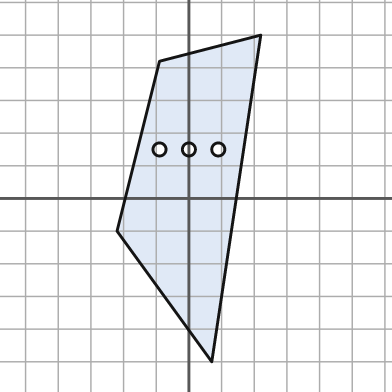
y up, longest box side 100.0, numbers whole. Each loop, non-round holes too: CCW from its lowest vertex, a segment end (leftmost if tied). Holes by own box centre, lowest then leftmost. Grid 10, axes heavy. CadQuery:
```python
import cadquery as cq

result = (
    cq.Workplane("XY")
    .moveTo(7.0, -50.0)
    .lineTo(22.0, 50.0)
    .lineTo(-9.0, 42.0)
    .lineTo(-22.0, -10.0)
    .close()
    .moveTo(-9.0, 15.0)
    .circle(2.0)
    .moveTo(0.0, 15.0)
    .circle(2.0)
    .moveTo(9.0, 15.0)
    .circle(2.0)
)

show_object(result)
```